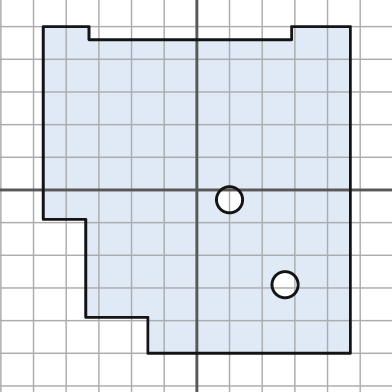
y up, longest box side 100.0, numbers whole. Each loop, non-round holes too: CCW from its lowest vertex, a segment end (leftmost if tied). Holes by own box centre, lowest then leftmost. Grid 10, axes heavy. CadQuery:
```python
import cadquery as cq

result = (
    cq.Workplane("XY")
    .moveTo(-15.0, -50.0)
    .lineTo(47.0, -50.0)
    .lineTo(47.0, 50.0)
    .lineTo(29.0, 50.0)
    .lineTo(29.0, 46.0)
    .lineTo(-33.0, 46.0)
    .lineTo(-33.0, 50.0)
    .lineTo(-47.0, 50.0)
    .lineTo(-47.0, -9.0)
    .lineTo(-34.0, -9.0)
    .lineTo(-34.0, -39.0)
    .lineTo(-15.0, -39.0)
    .close()
    .moveTo(27.0, -29.0)
    .circle(4.0)
    .moveTo(10.0, -3.0)
    .circle(4.0)
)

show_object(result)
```